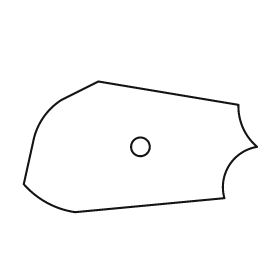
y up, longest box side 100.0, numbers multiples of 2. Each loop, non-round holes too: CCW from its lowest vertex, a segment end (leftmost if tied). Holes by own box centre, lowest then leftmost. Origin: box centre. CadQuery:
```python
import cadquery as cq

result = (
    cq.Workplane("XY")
    .moveTo(-28.0, -28.0)
    .lineTo(36.0, -22.0)
    .threePointArc((38.0, -8.0), (50.0, 0.0))
    .threePointArc((44.0, 8.0), (42.0, 18.0))
    .lineTo(-18.0, 28.0)
    .lineTo(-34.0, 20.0)
    .threePointArc((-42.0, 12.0), (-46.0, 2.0))
    .lineTo(-50.0, -16.0)
    .threePointArc((-40.0, -24.0), (-28.0, -28.0))
    .close()
    .moveTo(0.0, 0.0)
    .circle(4.0)
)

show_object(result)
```